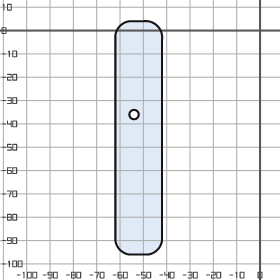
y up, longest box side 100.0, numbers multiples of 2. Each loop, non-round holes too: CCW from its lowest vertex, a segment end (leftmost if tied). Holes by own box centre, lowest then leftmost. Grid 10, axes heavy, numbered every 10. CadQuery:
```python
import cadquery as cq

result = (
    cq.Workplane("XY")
    .moveTo(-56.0, -96.0)
    .lineTo(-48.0, -96.0)
    .threePointArc((-44.0, -94.0), (-42.0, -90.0))
    .lineTo(-42.0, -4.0)
    .threePointArc((-44.0, 2.0), (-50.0, 4.0))
    .lineTo(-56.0, 4.0)
    .threePointArc((-60.0, 2.0), (-62.0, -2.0))
    .lineTo(-62.0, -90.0)
    .threePointArc((-60.0, -94.0), (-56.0, -96.0))
    .close()
    .moveTo(-54.0, -36.0)
    .circle(2.0)
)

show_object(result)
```